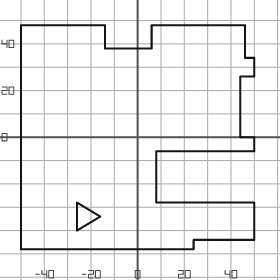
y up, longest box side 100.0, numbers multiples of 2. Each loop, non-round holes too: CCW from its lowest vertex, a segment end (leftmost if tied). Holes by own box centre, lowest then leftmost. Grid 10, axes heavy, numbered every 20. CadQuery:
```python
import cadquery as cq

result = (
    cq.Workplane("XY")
    .moveTo(-50.0, -48.0)
    .lineTo(24.0, -48.0)
    .lineTo(24.0, -44.0)
    .lineTo(50.0, -44.0)
    .lineTo(50.0, -28.0)
    .lineTo(8.0, -28.0)
    .lineTo(8.0, -6.0)
    .lineTo(50.0, -6.0)
    .lineTo(50.0, 0.0)
    .lineTo(44.0, 0.0)
    .lineTo(44.0, 26.0)
    .lineTo(50.0, 26.0)
    .lineTo(50.0, 34.0)
    .lineTo(46.0, 34.0)
    .lineTo(46.0, 48.0)
    .lineTo(6.0, 48.0)
    .lineTo(6.0, 38.0)
    .lineTo(-14.0, 38.0)
    .lineTo(-14.0, 48.0)
    .lineTo(-50.0, 48.0)
    .close()
    .moveTo(-26.0, -40.0)
    .lineTo(-16.0, -34.0)
    .lineTo(-26.0, -28.0)
    .close()
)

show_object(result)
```